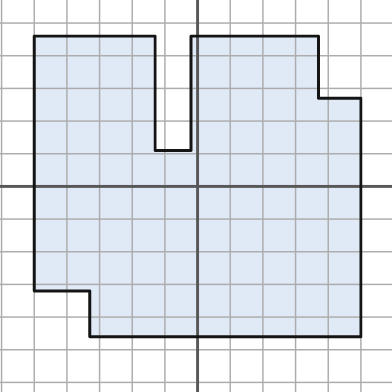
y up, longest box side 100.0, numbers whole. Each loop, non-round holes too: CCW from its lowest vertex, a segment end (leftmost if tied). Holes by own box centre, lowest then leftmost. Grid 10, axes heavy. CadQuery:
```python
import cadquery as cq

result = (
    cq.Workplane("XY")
    .moveTo(-33.0, -46.0)
    .lineTo(50.0, -46.0)
    .lineTo(50.0, 27.0)
    .lineTo(37.0, 27.0)
    .lineTo(37.0, 46.0)
    .lineTo(-2.0, 46.0)
    .lineTo(-2.0, 11.0)
    .lineTo(-13.0, 11.0)
    .lineTo(-13.0, 46.0)
    .lineTo(-50.0, 46.0)
    .lineTo(-50.0, -32.0)
    .lineTo(-33.0, -32.0)
    .close()
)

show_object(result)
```